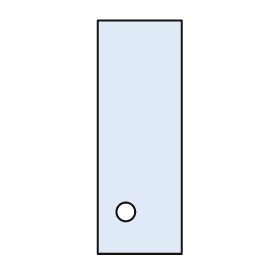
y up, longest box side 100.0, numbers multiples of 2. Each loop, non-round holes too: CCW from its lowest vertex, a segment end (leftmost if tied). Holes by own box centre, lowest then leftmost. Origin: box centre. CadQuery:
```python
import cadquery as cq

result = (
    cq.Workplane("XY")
    .moveTo(-18.0, -50.0)
    .lineTo(18.0, -50.0)
    .lineTo(18.0, 50.0)
    .lineTo(-18.0, 50.0)
    .close()
    .moveTo(-6.0, -32.0)
    .circle(4.0)
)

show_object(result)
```